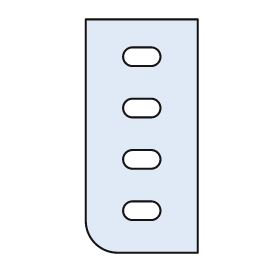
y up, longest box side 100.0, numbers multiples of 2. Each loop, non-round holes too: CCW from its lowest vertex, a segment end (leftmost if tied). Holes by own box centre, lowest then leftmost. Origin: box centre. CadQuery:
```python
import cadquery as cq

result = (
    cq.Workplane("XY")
    .moveTo(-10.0, -50.0)
    .lineTo(24.0, -50.0)
    .lineTo(24.0, 50.0)
    .lineTo(-24.0, 50.0)
    .lineTo(-24.0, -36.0)
    .threePointArc((-20.0, -46.0), (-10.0, -50.0))
    .close()
    .moveTo(-4.0, -36.0)
    .lineTo(4.0, -36.0)
    .threePointArc((8.0, -32.0), (4.0, -28.0))
    .lineTo(-4.0, -28.0)
    .threePointArc((-8.0, -32.0), (-4.0, -36.0))
    .close()
    .moveTo(-4.0, -14.0)
    .lineTo(4.0, -14.0)
    .threePointArc((8.0, -10.0), (4.0, -6.0))
    .lineTo(-4.0, -6.0)
    .threePointArc((-8.0, -10.0), (-4.0, -14.0))
    .close()
    .moveTo(-4.0, 8.0)
    .lineTo(4.0, 8.0)
    .threePointArc((8.0, 12.0), (4.0, 16.0))
    .lineTo(-4.0, 16.0)
    .threePointArc((-8.0, 12.0), (-4.0, 8.0))
    .close()
    .moveTo(-4.0, 30.0)
    .lineTo(4.0, 30.0)
    .threePointArc((8.0, 34.0), (4.0, 38.0))
    .lineTo(-4.0, 38.0)
    .threePointArc((-8.0, 34.0), (-4.0, 30.0))
    .close()
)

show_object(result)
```